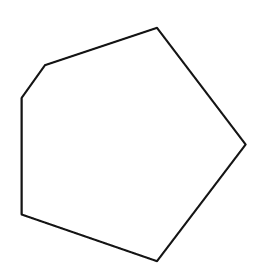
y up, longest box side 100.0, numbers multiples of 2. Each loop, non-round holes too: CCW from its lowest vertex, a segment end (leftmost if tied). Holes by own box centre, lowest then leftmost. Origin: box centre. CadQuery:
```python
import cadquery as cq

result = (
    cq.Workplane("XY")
    .moveTo(10.0, -50.0)
    .lineTo(48.0, 0.0)
    .lineTo(10.0, 50.0)
    .lineTo(-38.0, 34.0)
    .lineTo(-48.0, 20.0)
    .lineTo(-48.0, -30.0)
    .close()
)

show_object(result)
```